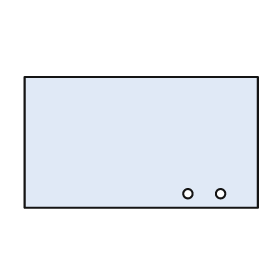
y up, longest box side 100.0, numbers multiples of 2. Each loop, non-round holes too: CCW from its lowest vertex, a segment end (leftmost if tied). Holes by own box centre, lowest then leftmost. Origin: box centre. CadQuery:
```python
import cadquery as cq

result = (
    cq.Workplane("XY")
    .moveTo(-50.0, -28.0)
    .lineTo(50.0, -28.0)
    .lineTo(50.0, 28.0)
    .lineTo(-50.0, 28.0)
    .close()
    .moveTo(20.0, -22.0)
    .circle(2.0)
    .moveTo(34.0, -22.0)
    .circle(2.0)
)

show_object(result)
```